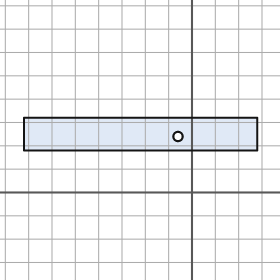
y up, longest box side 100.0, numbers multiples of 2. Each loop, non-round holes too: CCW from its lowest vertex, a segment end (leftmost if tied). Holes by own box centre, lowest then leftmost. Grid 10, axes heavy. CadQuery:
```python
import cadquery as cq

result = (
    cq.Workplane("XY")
    .moveTo(-72.0, 18.0)
    .lineTo(28.0, 18.0)
    .lineTo(28.0, 32.0)
    .lineTo(-72.0, 32.0)
    .close()
    .moveTo(-6.0, 24.0)
    .circle(2.0)
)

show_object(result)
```